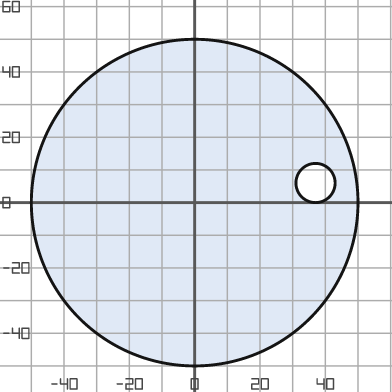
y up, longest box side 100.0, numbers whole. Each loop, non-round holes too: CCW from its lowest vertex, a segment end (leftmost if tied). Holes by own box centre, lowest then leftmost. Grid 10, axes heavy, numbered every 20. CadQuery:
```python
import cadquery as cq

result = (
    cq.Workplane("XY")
    .moveTo(0.0, 0.0)
    .circle(50.0)
    .moveTo(37.0, 6.0)
    .circle(6.0)
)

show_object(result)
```